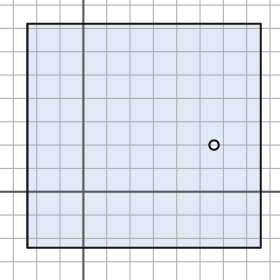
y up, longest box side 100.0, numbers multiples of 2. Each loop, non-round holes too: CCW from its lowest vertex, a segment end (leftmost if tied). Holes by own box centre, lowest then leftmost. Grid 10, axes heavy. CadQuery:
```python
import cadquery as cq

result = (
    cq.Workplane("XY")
    .moveTo(-24.0, -24.0)
    .lineTo(76.0, -24.0)
    .lineTo(76.0, 72.0)
    .lineTo(-24.0, 72.0)
    .close()
    .moveTo(56.0, 20.0)
    .circle(2.0)
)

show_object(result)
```